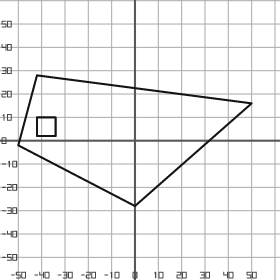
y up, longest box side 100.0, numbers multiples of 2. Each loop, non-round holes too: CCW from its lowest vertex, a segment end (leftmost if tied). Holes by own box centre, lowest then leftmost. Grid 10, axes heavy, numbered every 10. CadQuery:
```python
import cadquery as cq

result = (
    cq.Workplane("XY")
    .moveTo(0.0, -28.0)
    .lineTo(50.0, 16.0)
    .lineTo(-42.0, 28.0)
    .lineTo(-50.0, -2.0)
    .close()
    .moveTo(-42.0, 2.0)
    .lineTo(-34.0, 2.0)
    .lineTo(-34.0, 10.0)
    .lineTo(-42.0, 10.0)
    .close()
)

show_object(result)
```